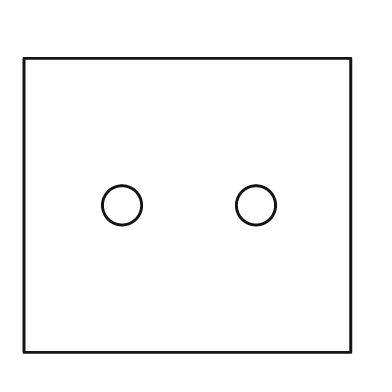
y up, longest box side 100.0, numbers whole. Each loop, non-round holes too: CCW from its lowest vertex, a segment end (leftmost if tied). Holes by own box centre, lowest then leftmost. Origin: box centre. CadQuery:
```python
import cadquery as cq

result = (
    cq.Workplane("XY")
    .moveTo(-50.0, -45.0)
    .lineTo(50.0, -45.0)
    .lineTo(50.0, 45.0)
    .lineTo(-50.0, 45.0)
    .close()
    .moveTo(-20.0, 0.0)
    .circle(6.0)
    .moveTo(21.0, 0.0)
    .circle(6.0)
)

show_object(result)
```